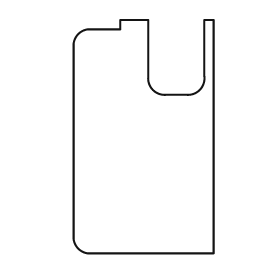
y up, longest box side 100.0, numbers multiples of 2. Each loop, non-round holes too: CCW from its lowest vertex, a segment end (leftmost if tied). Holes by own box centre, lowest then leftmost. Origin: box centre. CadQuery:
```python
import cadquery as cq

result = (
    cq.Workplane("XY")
    .moveTo(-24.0, -50.0)
    .lineTo(30.0, -50.0)
    .lineTo(30.0, 50.0)
    .lineTo(26.0, 50.0)
    .lineTo(26.0, 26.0)
    .threePointArc((24.0, 20.0), (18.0, 18.0))
    .lineTo(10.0, 18.0)
    .threePointArc((4.0, 20.0), (2.0, 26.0))
    .lineTo(2.0, 50.0)
    .lineTo(-10.0, 50.0)
    .lineTo(-10.0, 46.0)
    .lineTo(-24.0, 46.0)
    .threePointArc((-28.0, 44.0), (-30.0, 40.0))
    .lineTo(-30.0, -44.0)
    .threePointArc((-28.0, -48.0), (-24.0, -50.0))
    .close()
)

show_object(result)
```